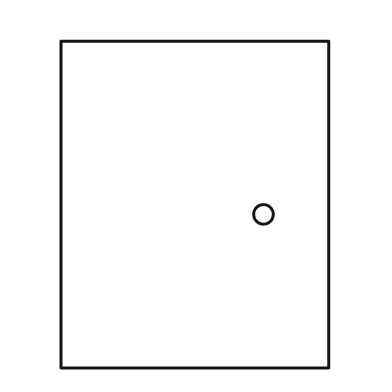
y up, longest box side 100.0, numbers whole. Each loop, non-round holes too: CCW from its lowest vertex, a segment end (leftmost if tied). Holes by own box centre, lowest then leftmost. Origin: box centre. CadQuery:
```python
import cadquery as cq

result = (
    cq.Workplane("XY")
    .moveTo(-41.0, -50.0)
    .lineTo(41.0, -50.0)
    .lineTo(41.0, 50.0)
    .lineTo(-41.0, 50.0)
    .close()
    .moveTo(21.0, -3.0)
    .circle(3.0)
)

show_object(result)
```